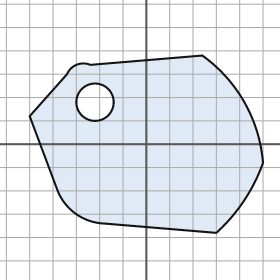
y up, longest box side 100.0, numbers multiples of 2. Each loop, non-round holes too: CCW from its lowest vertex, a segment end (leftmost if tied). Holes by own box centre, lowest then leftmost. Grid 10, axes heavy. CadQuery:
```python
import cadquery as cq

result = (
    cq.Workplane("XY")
    .moveTo(30.0, -38.0)
    .threePointArc((42.0, -24.0), (50.0, -8.0))
    .threePointArc((42.0, 18.0), (24.0, 38.0))
    .lineTo(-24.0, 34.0)
    .threePointArc((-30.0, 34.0), (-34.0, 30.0))
    .lineTo(-50.0, 12.0)
    .lineTo(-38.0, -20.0)
    .threePointArc((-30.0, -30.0), (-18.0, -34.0))
    .close()
    .moveTo(-22.0, 18.0)
    .circle(8.0)
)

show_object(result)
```